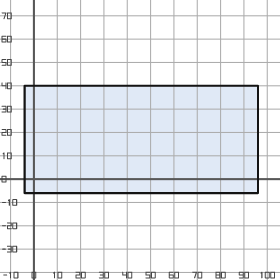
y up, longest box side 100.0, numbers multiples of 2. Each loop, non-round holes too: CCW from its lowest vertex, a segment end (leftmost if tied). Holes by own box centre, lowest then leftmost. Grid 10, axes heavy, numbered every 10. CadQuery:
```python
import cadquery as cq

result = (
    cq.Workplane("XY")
    .moveTo(-4.0, -6.0)
    .lineTo(96.0, -6.0)
    .lineTo(96.0, 40.0)
    .lineTo(-4.0, 40.0)
    .close()
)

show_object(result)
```